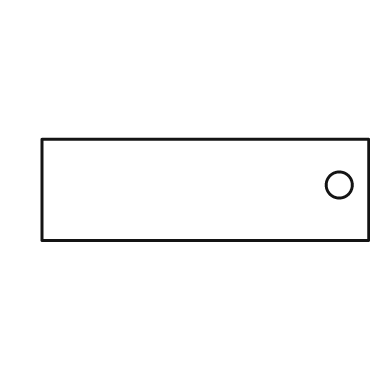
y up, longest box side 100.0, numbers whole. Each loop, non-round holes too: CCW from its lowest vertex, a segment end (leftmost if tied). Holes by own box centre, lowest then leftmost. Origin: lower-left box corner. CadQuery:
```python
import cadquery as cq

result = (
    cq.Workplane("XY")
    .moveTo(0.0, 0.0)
    .lineTo(100.0, 0.0)
    .lineTo(100.0, 31.0)
    .lineTo(0.0, 31.0)
    .close()
    .moveTo(91.0, 17.0)
    .circle(4.0)
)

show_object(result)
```